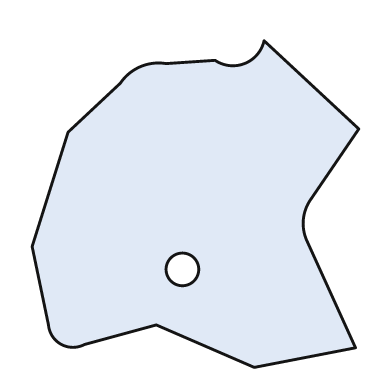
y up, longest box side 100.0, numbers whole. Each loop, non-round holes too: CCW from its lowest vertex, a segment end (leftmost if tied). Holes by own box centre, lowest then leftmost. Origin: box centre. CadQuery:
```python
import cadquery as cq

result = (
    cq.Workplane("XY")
    .moveTo(18.0, -50.0)
    .lineTo(49.0, -44.0)
    .lineTo(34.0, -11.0)
    .threePointArc((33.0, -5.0), (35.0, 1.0))
    .lineTo(50.0, 23.0)
    .lineTo(21.0, 50.0)
    .threePointArc((15.0, 43.0), (6.0, 44.0))
    .lineTo(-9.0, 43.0)
    .threePointArc((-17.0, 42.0), (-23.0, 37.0))
    .lineTo(-39.0, 22.0)
    .lineTo(-50.0, -13.0)
    .lineTo(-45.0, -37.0)
    .threePointArc((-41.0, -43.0), (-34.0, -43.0))
    .lineTo(-12.0, -37.0)
    .close()
    .moveTo(-4.0, -20.0)
    .circle(5.0)
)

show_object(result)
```